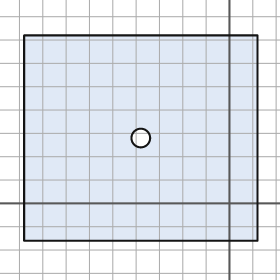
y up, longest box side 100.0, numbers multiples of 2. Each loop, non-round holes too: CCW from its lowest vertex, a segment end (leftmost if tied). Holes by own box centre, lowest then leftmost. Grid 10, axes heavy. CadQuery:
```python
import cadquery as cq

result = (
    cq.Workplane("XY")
    .moveTo(-88.0, -16.0)
    .lineTo(12.0, -16.0)
    .lineTo(12.0, 72.0)
    .lineTo(-88.0, 72.0)
    .close()
    .moveTo(-38.0, 28.0)
    .circle(4.0)
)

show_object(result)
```